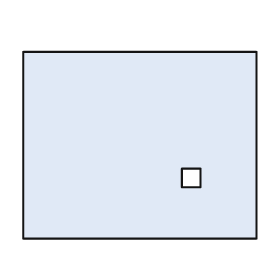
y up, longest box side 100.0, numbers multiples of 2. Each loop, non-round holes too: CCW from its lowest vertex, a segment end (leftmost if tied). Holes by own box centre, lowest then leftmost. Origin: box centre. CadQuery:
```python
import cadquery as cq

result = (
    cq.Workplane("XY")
    .moveTo(-50.0, -40.0)
    .lineTo(50.0, -40.0)
    .lineTo(50.0, 40.0)
    .lineTo(-50.0, 40.0)
    .close()
    .moveTo(18.0, -18.0)
    .lineTo(26.0, -18.0)
    .lineTo(26.0, -10.0)
    .lineTo(18.0, -10.0)
    .close()
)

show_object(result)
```